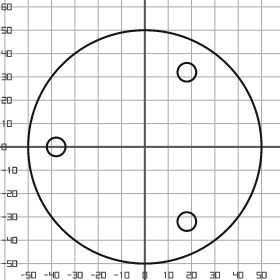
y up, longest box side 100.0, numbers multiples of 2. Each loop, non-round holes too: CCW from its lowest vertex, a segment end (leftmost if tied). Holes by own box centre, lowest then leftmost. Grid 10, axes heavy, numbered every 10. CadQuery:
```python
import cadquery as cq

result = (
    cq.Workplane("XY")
    .moveTo(0.0, 0.0)
    .circle(50.0)
    .moveTo(18.0, -32.0)
    .circle(4.0)
    .moveTo(-38.0, 0.0)
    .circle(4.0)
    .moveTo(18.0, 32.0)
    .circle(4.0)
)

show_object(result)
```